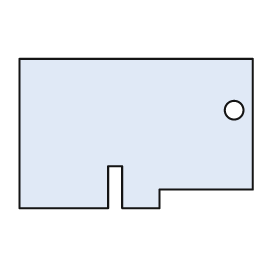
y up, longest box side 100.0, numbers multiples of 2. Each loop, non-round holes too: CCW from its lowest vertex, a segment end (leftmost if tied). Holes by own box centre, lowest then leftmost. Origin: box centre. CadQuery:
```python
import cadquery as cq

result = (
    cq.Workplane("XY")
    .moveTo(-50.0, -32.0)
    .lineTo(-12.0, -32.0)
    .lineTo(-12.0, -14.0)
    .lineTo(-6.0, -14.0)
    .lineTo(-6.0, -32.0)
    .lineTo(10.0, -32.0)
    .lineTo(10.0, -24.0)
    .lineTo(50.0, -24.0)
    .lineTo(50.0, 32.0)
    .lineTo(-50.0, 32.0)
    .close()
    .moveTo(42.0, 10.0)
    .circle(4.0)
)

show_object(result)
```